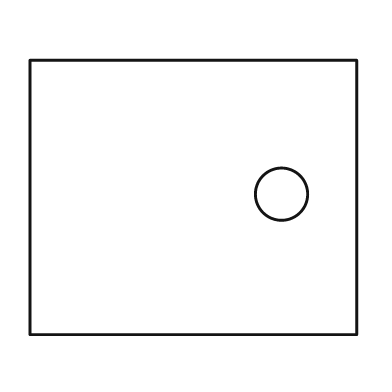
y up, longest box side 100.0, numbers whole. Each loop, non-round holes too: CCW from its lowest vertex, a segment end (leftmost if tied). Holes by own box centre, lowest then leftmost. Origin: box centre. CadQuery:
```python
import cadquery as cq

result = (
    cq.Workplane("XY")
    .moveTo(-50.0, -42.0)
    .lineTo(50.0, -42.0)
    .lineTo(50.0, 42.0)
    .lineTo(-50.0, 42.0)
    .close()
    .moveTo(27.0, 1.0)
    .circle(8.0)
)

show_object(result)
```